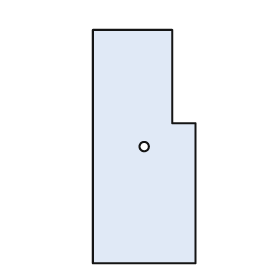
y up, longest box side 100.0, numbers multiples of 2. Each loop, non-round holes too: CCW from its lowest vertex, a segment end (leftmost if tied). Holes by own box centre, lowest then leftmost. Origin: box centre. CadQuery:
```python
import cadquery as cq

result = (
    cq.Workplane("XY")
    .moveTo(-22.0, -50.0)
    .lineTo(22.0, -50.0)
    .lineTo(22.0, 10.0)
    .lineTo(12.0, 10.0)
    .lineTo(12.0, 50.0)
    .lineTo(-22.0, 50.0)
    .close()
    .moveTo(0.0, 0.0)
    .circle(2.0)
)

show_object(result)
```